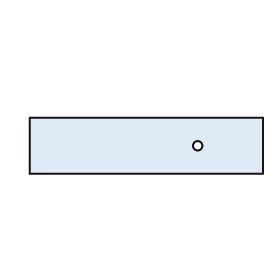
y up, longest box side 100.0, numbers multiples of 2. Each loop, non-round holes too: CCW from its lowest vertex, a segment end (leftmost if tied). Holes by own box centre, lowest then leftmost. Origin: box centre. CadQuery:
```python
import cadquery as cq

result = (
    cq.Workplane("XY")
    .moveTo(-50.0, -12.0)
    .lineTo(50.0, -12.0)
    .lineTo(50.0, 12.0)
    .lineTo(-50.0, 12.0)
    .close()
    .moveTo(22.0, 0.0)
    .circle(2.0)
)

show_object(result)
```